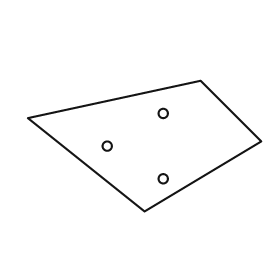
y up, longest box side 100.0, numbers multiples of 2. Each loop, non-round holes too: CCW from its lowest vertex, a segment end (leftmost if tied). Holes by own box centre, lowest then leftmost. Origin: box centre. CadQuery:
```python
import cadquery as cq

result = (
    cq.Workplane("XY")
    .moveTo(0.0, -28.0)
    .lineTo(50.0, 2.0)
    .lineTo(24.0, 28.0)
    .lineTo(-50.0, 12.0)
    .close()
    .moveTo(8.0, -14.0)
    .circle(2.0)
    .moveTo(-16.0, 0.0)
    .circle(2.0)
    .moveTo(8.0, 14.0)
    .circle(2.0)
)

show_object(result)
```